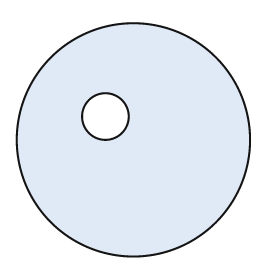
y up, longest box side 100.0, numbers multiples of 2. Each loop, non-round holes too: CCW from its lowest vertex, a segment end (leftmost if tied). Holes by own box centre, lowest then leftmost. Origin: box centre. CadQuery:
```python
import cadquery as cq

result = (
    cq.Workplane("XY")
    .moveTo(0.0, 0.0)
    .circle(50.0)
    .moveTo(-12.0, 10.0)
    .circle(10.0)
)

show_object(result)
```